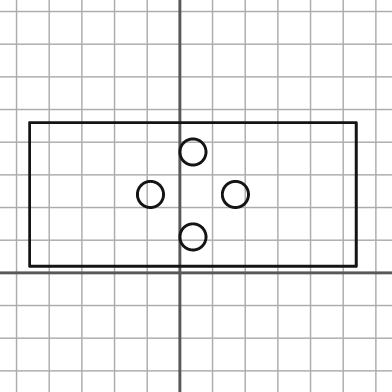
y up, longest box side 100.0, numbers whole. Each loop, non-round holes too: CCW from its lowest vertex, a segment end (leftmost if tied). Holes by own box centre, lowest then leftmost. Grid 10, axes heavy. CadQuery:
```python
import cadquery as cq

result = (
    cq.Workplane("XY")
    .moveTo(-46.0, 2.0)
    .lineTo(54.0, 2.0)
    .lineTo(54.0, 46.0)
    .lineTo(-46.0, 46.0)
    .close()
    .moveTo(4.0, 11.0)
    .circle(4.0)
    .moveTo(-9.0, 24.0)
    .circle(4.0)
    .moveTo(17.0, 24.0)
    .circle(4.0)
    .moveTo(4.0, 37.0)
    .circle(4.0)
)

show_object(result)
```